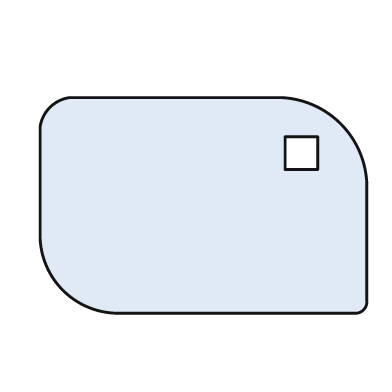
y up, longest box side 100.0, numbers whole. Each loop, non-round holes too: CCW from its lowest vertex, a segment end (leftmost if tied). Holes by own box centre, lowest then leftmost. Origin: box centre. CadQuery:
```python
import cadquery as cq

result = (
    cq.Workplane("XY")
    .moveTo(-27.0, -33.0)
    .lineTo(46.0, -33.0)
    .threePointArc((49.0, -32.0), (50.0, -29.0))
    .lineTo(50.0, 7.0)
    .threePointArc((42.0, 25.0), (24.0, 33.0))
    .lineTo(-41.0, 33.0)
    .threePointArc((-47.0, 30.0), (-50.0, 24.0))
    .lineTo(-50.0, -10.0)
    .threePointArc((-43.0, -26.0), (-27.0, -33.0))
    .close()
    .moveTo(25.0, 11.0)
    .lineTo(35.0, 11.0)
    .lineTo(35.0, 21.0)
    .lineTo(25.0, 21.0)
    .close()
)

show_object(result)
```